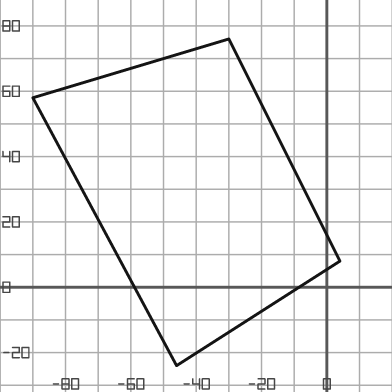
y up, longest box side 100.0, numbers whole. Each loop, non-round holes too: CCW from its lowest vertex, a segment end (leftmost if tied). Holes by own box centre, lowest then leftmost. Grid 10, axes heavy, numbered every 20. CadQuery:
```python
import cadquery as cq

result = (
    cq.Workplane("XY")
    .moveTo(-46.0, -24.0)
    .lineTo(4.0, 8.0)
    .lineTo(-30.0, 76.0)
    .lineTo(-90.0, 58.0)
    .close()
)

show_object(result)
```